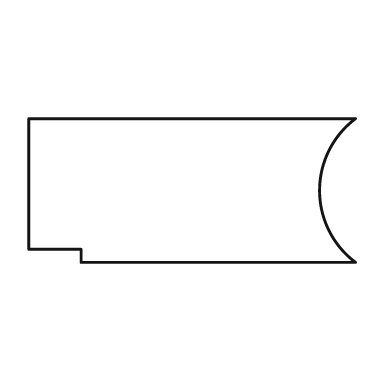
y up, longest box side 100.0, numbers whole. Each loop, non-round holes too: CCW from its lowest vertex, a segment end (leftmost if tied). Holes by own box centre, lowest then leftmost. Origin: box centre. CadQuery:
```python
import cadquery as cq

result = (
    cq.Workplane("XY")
    .moveTo(-34.0, -22.0)
    .lineTo(50.0, -22.0)
    .threePointArc((39.0, 0.0), (50.0, 22.0))
    .lineTo(-50.0, 22.0)
    .lineTo(-50.0, -18.0)
    .lineTo(-34.0, -18.0)
    .close()
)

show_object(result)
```